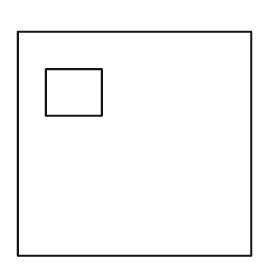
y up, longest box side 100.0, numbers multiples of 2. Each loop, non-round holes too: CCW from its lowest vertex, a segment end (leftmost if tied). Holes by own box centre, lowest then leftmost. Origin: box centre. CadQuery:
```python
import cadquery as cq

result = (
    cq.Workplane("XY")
    .moveTo(-50.0, -48.0)
    .lineTo(50.0, -48.0)
    .lineTo(50.0, 48.0)
    .lineTo(-50.0, 48.0)
    .close()
    .moveTo(-38.0, 12.0)
    .lineTo(-14.0, 12.0)
    .lineTo(-14.0, 32.0)
    .lineTo(-38.0, 32.0)
    .close()
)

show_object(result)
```